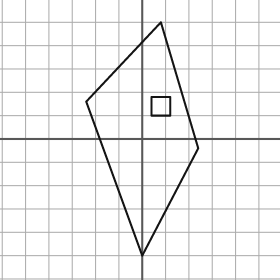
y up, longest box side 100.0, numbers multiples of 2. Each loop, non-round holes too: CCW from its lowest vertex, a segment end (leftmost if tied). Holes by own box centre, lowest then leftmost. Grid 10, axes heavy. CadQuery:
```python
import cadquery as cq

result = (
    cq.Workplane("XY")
    .moveTo(0.0, -50.0)
    .lineTo(24.0, -4.0)
    .lineTo(8.0, 50.0)
    .lineTo(-24.0, 16.0)
    .close()
    .moveTo(4.0, 10.0)
    .lineTo(12.0, 10.0)
    .lineTo(12.0, 18.0)
    .lineTo(4.0, 18.0)
    .close()
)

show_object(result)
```